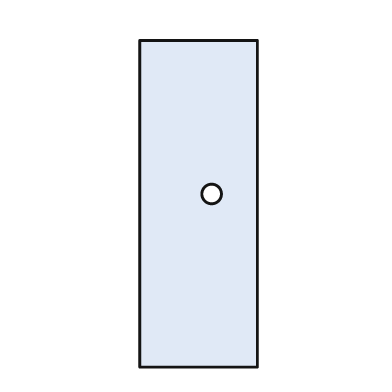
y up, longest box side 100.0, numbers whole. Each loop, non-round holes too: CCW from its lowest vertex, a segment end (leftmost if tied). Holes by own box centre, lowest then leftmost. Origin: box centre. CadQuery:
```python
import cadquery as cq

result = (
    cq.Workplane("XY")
    .moveTo(-18.0, -50.0)
    .lineTo(18.0, -50.0)
    .lineTo(18.0, 50.0)
    .lineTo(-18.0, 50.0)
    .close()
    .moveTo(4.0, 3.0)
    .circle(3.0)
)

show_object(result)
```